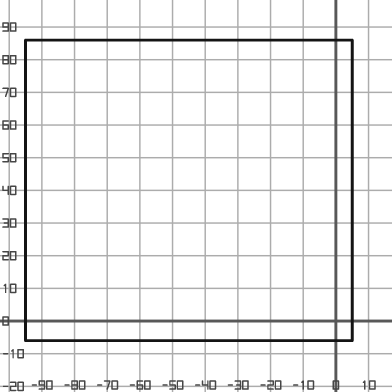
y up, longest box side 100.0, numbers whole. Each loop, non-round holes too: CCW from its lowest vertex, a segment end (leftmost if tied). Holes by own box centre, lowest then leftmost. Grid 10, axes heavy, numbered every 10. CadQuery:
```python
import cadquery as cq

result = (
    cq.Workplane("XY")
    .moveTo(-95.0, -6.0)
    .lineTo(5.0, -6.0)
    .lineTo(5.0, 86.0)
    .lineTo(-95.0, 86.0)
    .close()
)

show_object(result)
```